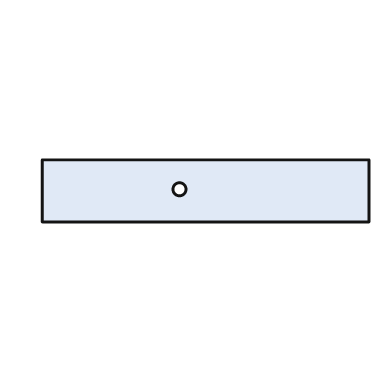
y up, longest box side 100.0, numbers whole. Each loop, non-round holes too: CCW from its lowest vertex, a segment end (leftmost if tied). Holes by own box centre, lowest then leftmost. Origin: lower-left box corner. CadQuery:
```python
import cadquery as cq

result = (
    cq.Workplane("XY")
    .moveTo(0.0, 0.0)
    .lineTo(100.0, 0.0)
    .lineTo(100.0, 19.0)
    .lineTo(0.0, 19.0)
    .close()
    .moveTo(42.0, 10.0)
    .circle(2.0)
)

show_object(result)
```